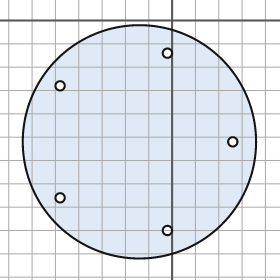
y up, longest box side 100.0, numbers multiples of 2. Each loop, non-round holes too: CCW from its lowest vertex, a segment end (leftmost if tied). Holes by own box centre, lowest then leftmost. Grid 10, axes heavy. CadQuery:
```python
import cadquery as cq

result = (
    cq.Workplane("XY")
    .moveTo(-14.0, -52.0)
    .circle(50.0)
    .moveTo(-2.0, -90.0)
    .circle(2.0)
    .moveTo(-48.0, -76.0)
    .circle(2.0)
    .moveTo(26.0, -52.0)
    .circle(2.0)
    .moveTo(-48.0, -28.0)
    .circle(2.0)
    .moveTo(-2.0, -14.0)
    .circle(2.0)
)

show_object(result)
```